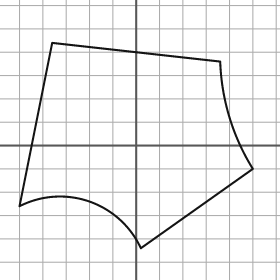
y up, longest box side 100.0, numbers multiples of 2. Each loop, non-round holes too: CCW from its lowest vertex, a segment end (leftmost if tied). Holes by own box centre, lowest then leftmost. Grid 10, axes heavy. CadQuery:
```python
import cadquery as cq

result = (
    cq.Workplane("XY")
    .moveTo(2.0, -44.0)
    .lineTo(50.0, -10.0)
    .threePointArc((40.0, 12.0), (36.0, 36.0))
    .lineTo(-36.0, 44.0)
    .lineTo(-50.0, -26.0)
    .threePointArc((-20.0, -24.0), (2.0, -44.0))
    .close()
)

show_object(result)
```